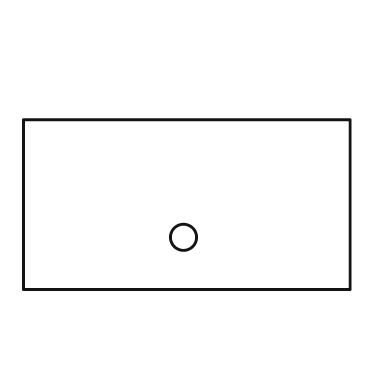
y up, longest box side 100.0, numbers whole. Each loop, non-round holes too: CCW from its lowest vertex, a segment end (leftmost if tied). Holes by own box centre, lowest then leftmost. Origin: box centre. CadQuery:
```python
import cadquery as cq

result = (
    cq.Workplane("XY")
    .moveTo(-50.0, -26.0)
    .lineTo(50.0, -26.0)
    .lineTo(50.0, 26.0)
    .lineTo(-50.0, 26.0)
    .close()
    .moveTo(-1.0, -10.0)
    .circle(4.0)
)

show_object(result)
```